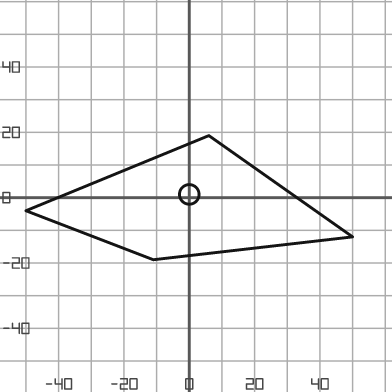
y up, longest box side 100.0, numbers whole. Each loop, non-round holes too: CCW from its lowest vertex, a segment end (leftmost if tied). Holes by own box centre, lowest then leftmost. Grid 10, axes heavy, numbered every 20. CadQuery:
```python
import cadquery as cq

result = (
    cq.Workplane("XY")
    .moveTo(-11.0, -19.0)
    .lineTo(50.0, -12.0)
    .lineTo(6.0, 19.0)
    .lineTo(-50.0, -4.0)
    .close()
    .moveTo(0.0, 1.0)
    .circle(3.0)
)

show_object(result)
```